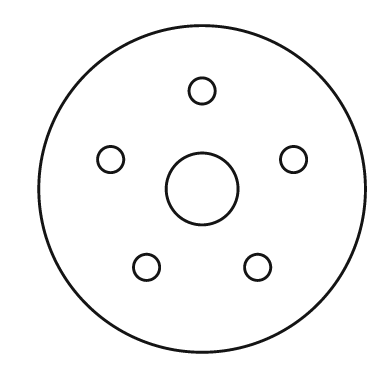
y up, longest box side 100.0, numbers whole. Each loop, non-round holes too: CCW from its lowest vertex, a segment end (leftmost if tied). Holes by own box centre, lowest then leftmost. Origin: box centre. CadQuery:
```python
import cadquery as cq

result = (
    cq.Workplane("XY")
    .moveTo(0.0, 0.0)
    .circle(50.0)
    .moveTo(-17.0, -24.0)
    .circle(4.0)
    .moveTo(17.0, -24.0)
    .circle(4.0)
    .moveTo(0.0, 0.0)
    .circle(11.0)
    .moveTo(-28.0, 9.0)
    .circle(4.0)
    .moveTo(28.0, 9.0)
    .circle(4.0)
    .moveTo(0.0, 30.0)
    .circle(4.0)
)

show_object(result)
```